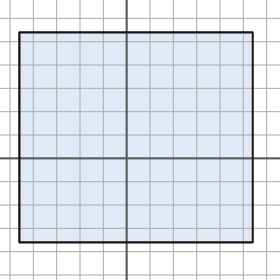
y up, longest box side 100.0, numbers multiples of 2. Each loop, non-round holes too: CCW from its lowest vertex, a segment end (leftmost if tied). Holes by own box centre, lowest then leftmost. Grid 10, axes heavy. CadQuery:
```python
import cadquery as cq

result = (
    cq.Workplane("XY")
    .moveTo(-46.0, -36.0)
    .lineTo(54.0, -36.0)
    .lineTo(54.0, 54.0)
    .lineTo(-46.0, 54.0)
    .close()
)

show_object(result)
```